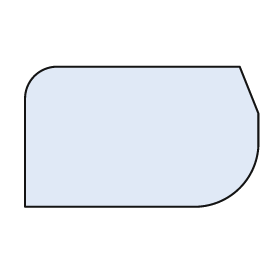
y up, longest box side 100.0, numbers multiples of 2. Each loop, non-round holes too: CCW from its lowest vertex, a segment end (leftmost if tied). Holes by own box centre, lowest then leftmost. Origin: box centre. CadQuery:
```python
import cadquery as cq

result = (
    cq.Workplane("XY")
    .moveTo(-50.0, -30.0)
    .lineTo(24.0, -30.0)
    .threePointArc((42.0, -22.0), (50.0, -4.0))
    .lineTo(50.0, 10.0)
    .lineTo(42.0, 30.0)
    .lineTo(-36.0, 30.0)
    .threePointArc((-46.0, 26.0), (-50.0, 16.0))
    .close()
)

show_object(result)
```